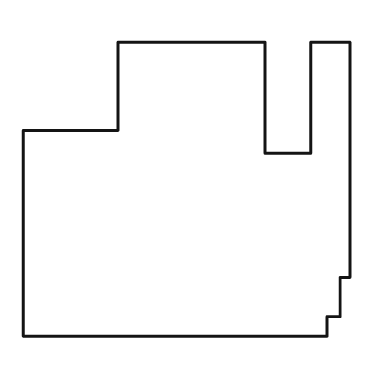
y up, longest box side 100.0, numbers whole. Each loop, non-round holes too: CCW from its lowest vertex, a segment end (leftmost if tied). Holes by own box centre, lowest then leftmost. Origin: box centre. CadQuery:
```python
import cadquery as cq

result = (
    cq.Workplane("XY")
    .moveTo(-50.0, -45.0)
    .lineTo(43.0, -45.0)
    .lineTo(43.0, -39.0)
    .lineTo(47.0, -39.0)
    .lineTo(47.0, -27.0)
    .lineTo(50.0, -27.0)
    .lineTo(50.0, 45.0)
    .lineTo(38.0, 45.0)
    .lineTo(38.0, 11.0)
    .lineTo(24.0, 11.0)
    .lineTo(24.0, 45.0)
    .lineTo(-21.0, 45.0)
    .lineTo(-21.0, 18.0)
    .lineTo(-50.0, 18.0)
    .close()
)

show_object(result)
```